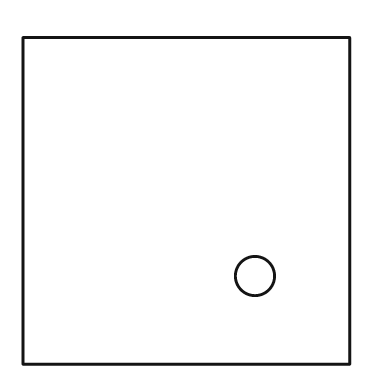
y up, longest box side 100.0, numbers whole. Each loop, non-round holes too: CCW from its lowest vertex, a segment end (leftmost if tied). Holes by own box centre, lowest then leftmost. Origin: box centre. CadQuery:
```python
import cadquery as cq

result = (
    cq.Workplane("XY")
    .moveTo(-50.0, -50.0)
    .lineTo(50.0, -50.0)
    .lineTo(50.0, 50.0)
    .lineTo(-50.0, 50.0)
    .close()
    .moveTo(21.0, -23.0)
    .circle(6.0)
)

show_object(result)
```